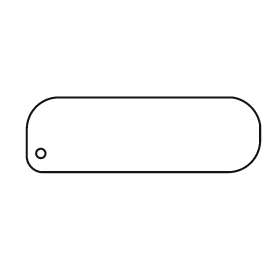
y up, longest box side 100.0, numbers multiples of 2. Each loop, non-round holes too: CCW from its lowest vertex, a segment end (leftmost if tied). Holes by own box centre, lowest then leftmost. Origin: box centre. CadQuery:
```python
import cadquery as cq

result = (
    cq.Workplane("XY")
    .moveTo(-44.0, -16.0)
    .lineTo(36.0, -16.0)
    .threePointArc((46.0, -12.0), (50.0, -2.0))
    .lineTo(50.0, 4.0)
    .threePointArc((46.0, 12.0), (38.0, 16.0))
    .lineTo(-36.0, 16.0)
    .threePointArc((-46.0, 12.0), (-50.0, 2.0))
    .lineTo(-50.0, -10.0)
    .threePointArc((-48.0, -14.0), (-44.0, -16.0))
    .close()
    .moveTo(-44.0, -8.0)
    .circle(2.0)
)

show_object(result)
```